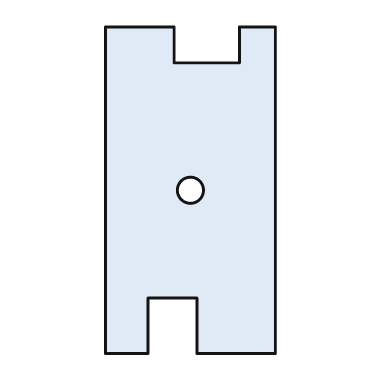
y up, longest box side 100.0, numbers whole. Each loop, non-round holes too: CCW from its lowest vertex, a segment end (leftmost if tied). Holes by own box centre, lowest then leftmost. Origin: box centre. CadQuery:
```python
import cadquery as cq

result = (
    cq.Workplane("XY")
    .moveTo(-26.0, -50.0)
    .lineTo(-13.0, -50.0)
    .lineTo(-13.0, -33.0)
    .lineTo(2.0, -33.0)
    .lineTo(2.0, -50.0)
    .lineTo(26.0, -50.0)
    .lineTo(26.0, 50.0)
    .lineTo(15.0, 50.0)
    .lineTo(15.0, 39.0)
    .lineTo(-5.0, 39.0)
    .lineTo(-5.0, 50.0)
    .lineTo(-26.0, 50.0)
    .close()
    .moveTo(0.0, 0.0)
    .circle(4.0)
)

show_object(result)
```